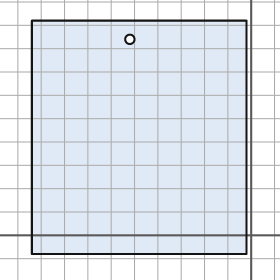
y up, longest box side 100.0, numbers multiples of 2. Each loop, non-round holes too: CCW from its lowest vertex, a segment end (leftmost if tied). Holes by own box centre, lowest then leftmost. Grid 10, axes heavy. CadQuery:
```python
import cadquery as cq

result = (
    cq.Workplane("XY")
    .moveTo(-94.0, -8.0)
    .lineTo(-2.0, -8.0)
    .lineTo(-2.0, 92.0)
    .lineTo(-94.0, 92.0)
    .close()
    .moveTo(-52.0, 84.0)
    .circle(2.0)
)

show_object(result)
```